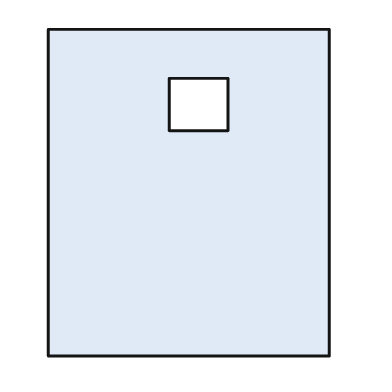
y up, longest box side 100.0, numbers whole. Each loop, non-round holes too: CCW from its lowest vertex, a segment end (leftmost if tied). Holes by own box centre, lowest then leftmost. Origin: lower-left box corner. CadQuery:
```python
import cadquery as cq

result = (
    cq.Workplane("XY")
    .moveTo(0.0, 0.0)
    .lineTo(86.0, 0.0)
    .lineTo(86.0, 100.0)
    .lineTo(0.0, 100.0)
    .close()
    .moveTo(37.0, 69.0)
    .lineTo(55.0, 69.0)
    .lineTo(55.0, 85.0)
    .lineTo(37.0, 85.0)
    .close()
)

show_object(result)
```